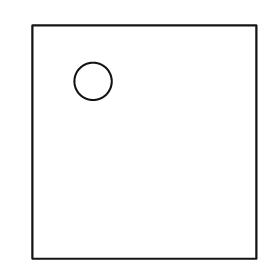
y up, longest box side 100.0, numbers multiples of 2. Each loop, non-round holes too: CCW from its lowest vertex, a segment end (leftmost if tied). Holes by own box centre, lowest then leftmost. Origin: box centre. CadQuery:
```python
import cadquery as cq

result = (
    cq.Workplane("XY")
    .moveTo(-48.0, -50.0)
    .lineTo(48.0, -50.0)
    .lineTo(48.0, 50.0)
    .lineTo(-48.0, 50.0)
    .close()
    .moveTo(-22.0, 26.0)
    .circle(8.0)
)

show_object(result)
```